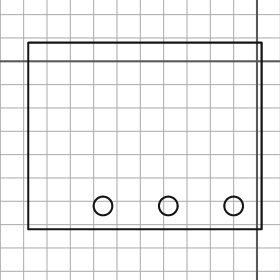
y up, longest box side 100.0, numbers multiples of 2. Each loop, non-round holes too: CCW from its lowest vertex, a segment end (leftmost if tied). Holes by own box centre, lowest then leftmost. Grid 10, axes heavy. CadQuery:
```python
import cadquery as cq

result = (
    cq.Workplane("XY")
    .moveTo(-98.0, -72.0)
    .lineTo(2.0, -72.0)
    .lineTo(2.0, 8.0)
    .lineTo(-98.0, 8.0)
    .close()
    .moveTo(-66.0, -62.0)
    .circle(4.0)
    .moveTo(-38.0, -62.0)
    .circle(4.0)
    .moveTo(-10.0, -62.0)
    .circle(4.0)
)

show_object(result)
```